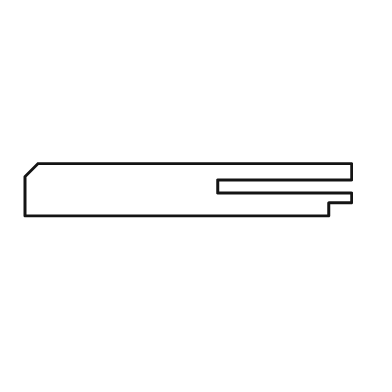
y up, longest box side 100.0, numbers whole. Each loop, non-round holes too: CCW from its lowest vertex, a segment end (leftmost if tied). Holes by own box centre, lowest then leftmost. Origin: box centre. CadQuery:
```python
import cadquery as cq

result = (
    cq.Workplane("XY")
    .moveTo(-50.0, -8.0)
    .lineTo(43.0, -8.0)
    .lineTo(43.0, -4.0)
    .lineTo(50.0, -4.0)
    .lineTo(50.0, -1.0)
    .lineTo(9.0, -1.0)
    .lineTo(9.0, 3.0)
    .lineTo(50.0, 3.0)
    .lineTo(50.0, 8.0)
    .lineTo(-46.0, 8.0)
    .lineTo(-50.0, 4.0)
    .close()
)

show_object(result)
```